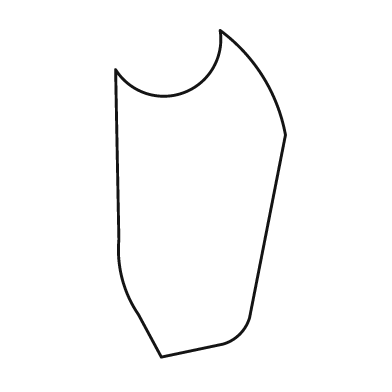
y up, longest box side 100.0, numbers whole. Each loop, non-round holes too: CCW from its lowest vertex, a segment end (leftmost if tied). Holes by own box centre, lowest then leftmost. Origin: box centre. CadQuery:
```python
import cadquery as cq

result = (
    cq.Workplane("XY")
    .moveTo(-12.0, -50.0)
    .lineTo(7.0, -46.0)
    .threePointArc((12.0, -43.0), (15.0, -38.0))
    .lineTo(26.0, 18.0)
    .threePointArc((19.0, 36.0), (6.0, 50.0))
    .threePointArc((-5.0, 31.0), (-26.0, 38.0))
    .lineTo(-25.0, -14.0)
    .threePointArc((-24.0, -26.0), (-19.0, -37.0))
    .close()
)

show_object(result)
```